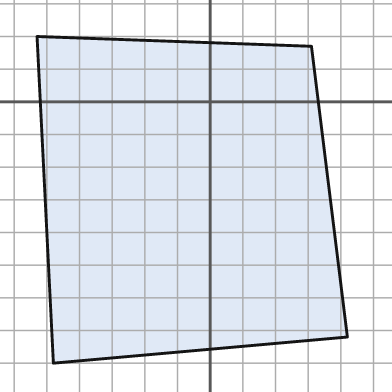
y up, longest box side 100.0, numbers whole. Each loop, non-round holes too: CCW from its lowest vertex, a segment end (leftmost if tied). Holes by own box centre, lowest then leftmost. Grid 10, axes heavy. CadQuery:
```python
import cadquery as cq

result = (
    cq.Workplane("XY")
    .moveTo(-48.0, -80.0)
    .lineTo(42.0, -72.0)
    .lineTo(31.0, 17.0)
    .lineTo(-53.0, 20.0)
    .close()
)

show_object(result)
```